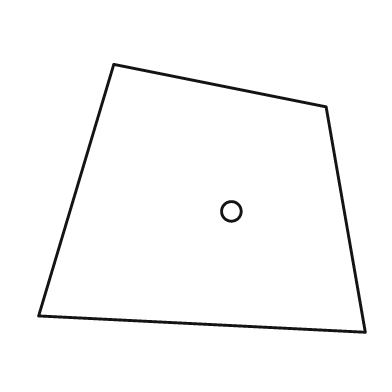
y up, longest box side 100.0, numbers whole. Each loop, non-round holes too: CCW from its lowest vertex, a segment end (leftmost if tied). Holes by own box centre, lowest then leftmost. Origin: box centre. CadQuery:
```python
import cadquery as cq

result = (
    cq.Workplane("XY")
    .moveTo(50.0, -41.0)
    .lineTo(38.0, 28.0)
    .lineTo(-27.0, 41.0)
    .lineTo(-50.0, -36.0)
    .close()
    .moveTo(9.0, -4.0)
    .circle(3.0)
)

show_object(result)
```